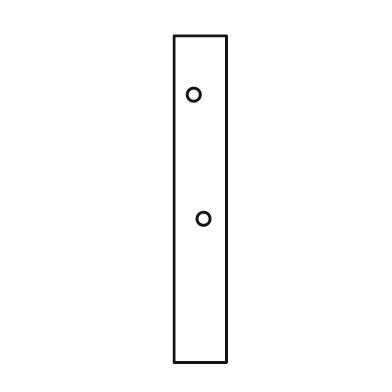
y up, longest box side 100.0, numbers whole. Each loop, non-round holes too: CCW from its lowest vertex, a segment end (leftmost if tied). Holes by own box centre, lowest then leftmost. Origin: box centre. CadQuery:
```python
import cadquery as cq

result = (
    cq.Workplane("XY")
    .moveTo(-8.0, -50.0)
    .lineTo(8.0, -50.0)
    .lineTo(8.0, 50.0)
    .lineTo(-8.0, 50.0)
    .close()
    .moveTo(1.0, -6.0)
    .circle(2.0)
    .moveTo(-2.0, 32.0)
    .circle(2.0)
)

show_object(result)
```